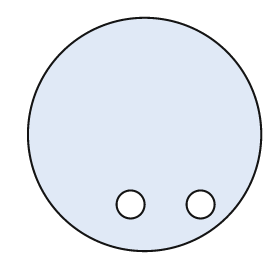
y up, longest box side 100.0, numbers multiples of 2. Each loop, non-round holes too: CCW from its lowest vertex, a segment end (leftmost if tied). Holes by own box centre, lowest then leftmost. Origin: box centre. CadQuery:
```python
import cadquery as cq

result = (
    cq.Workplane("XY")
    .moveTo(0.0, 0.0)
    .circle(50.0)
    .moveTo(-6.0, -30.0)
    .circle(6.0)
    .moveTo(24.0, -30.0)
    .circle(6.0)
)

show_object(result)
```